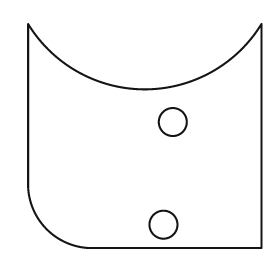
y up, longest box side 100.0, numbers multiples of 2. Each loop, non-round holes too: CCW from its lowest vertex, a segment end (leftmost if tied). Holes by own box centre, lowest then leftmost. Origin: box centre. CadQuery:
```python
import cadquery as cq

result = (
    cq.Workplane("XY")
    .moveTo(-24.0, -48.0)
    .lineTo(50.0, -48.0)
    .lineTo(50.0, 48.0)
    .threePointArc((0.0, 20.0), (-50.0, 48.0))
    .lineTo(-50.0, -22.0)
    .threePointArc((-42.0, -40.0), (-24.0, -48.0))
    .close()
    .moveTo(8.0, -38.0)
    .circle(6.0)
    .moveTo(12.0, 6.0)
    .circle(6.0)
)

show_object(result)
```